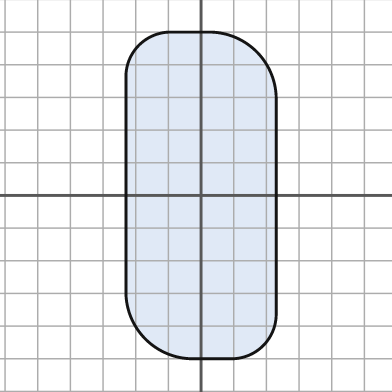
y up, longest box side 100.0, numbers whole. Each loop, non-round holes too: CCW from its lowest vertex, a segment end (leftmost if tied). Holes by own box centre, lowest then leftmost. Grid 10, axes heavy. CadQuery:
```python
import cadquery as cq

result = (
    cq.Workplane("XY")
    .moveTo(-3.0, -50.0)
    .lineTo(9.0, -50.0)
    .threePointArc((19.0, -46.0), (23.0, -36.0))
    .lineTo(23.0, 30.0)
    .threePointArc((17.0, 44.0), (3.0, 50.0))
    .lineTo(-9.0, 50.0)
    .threePointArc((-19.0, 46.0), (-23.0, 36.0))
    .lineTo(-23.0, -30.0)
    .threePointArc((-17.0, -44.0), (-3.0, -50.0))
    .close()
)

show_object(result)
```